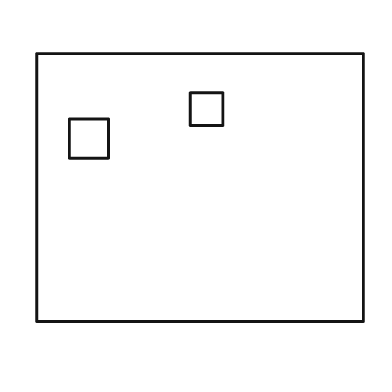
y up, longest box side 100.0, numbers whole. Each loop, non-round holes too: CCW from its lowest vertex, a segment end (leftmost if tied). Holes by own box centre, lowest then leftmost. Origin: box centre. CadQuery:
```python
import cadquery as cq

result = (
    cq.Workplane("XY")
    .moveTo(-50.0, -41.0)
    .lineTo(50.0, -41.0)
    .lineTo(50.0, 41.0)
    .lineTo(-50.0, 41.0)
    .close()
    .moveTo(-40.0, 9.0)
    .lineTo(-28.0, 9.0)
    .lineTo(-28.0, 21.0)
    .lineTo(-40.0, 21.0)
    .close()
    .moveTo(-3.0, 19.0)
    .lineTo(7.0, 19.0)
    .lineTo(7.0, 29.0)
    .lineTo(-3.0, 29.0)
    .close()
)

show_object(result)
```